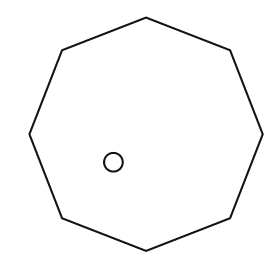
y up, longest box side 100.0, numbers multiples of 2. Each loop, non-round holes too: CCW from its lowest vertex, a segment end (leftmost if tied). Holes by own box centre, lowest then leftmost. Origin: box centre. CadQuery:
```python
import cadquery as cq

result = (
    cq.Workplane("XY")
    .moveTo(0.0, -50.0)
    .lineTo(36.0, -36.0)
    .lineTo(50.0, 0.0)
    .lineTo(36.0, 36.0)
    .lineTo(0.0, 50.0)
    .lineTo(-36.0, 36.0)
    .lineTo(-50.0, 0.0)
    .lineTo(-36.0, -36.0)
    .close()
    .moveTo(-14.0, -12.0)
    .circle(4.0)
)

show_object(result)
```